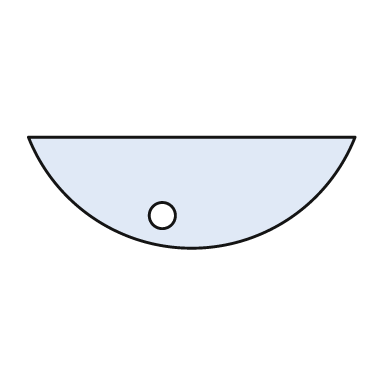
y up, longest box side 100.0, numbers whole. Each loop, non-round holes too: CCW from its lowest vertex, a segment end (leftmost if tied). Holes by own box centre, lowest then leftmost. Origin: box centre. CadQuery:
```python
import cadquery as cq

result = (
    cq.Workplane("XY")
    .moveTo(-50.0, 17.0)
    .threePointArc((0.0, -17.0), (50.0, 17.0))
    .close()
    .moveTo(-9.0, -7.0)
    .circle(4.0)
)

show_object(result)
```